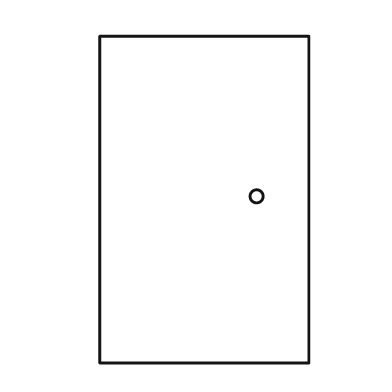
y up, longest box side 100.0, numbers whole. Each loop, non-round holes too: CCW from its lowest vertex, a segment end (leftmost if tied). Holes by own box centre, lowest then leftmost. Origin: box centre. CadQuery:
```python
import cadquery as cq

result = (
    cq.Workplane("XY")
    .moveTo(-32.0, -50.0)
    .lineTo(32.0, -50.0)
    .lineTo(32.0, 50.0)
    .lineTo(-32.0, 50.0)
    .close()
    .moveTo(16.0, 1.0)
    .circle(2.0)
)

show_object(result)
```